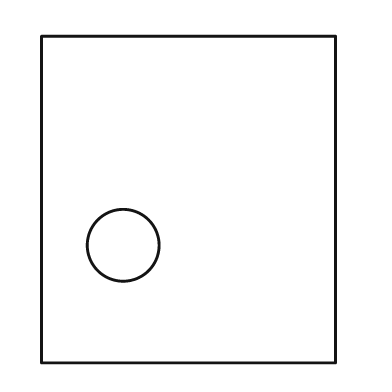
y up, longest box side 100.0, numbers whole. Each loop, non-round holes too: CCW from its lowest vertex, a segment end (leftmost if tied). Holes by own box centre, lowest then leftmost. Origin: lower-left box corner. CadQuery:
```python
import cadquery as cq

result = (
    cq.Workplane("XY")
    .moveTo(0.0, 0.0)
    .lineTo(90.0, 0.0)
    .lineTo(90.0, 100.0)
    .lineTo(0.0, 100.0)
    .close()
    .moveTo(25.0, 36.0)
    .circle(11.0)
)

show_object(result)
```